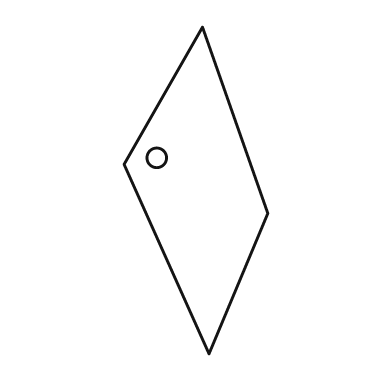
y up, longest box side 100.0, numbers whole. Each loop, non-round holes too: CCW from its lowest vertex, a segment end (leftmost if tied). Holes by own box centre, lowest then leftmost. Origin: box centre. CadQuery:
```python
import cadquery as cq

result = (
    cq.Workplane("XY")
    .moveTo(4.0, -50.0)
    .lineTo(22.0, -7.0)
    .lineTo(2.0, 50.0)
    .lineTo(-22.0, 8.0)
    .close()
    .moveTo(-12.0, 10.0)
    .circle(3.0)
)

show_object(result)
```